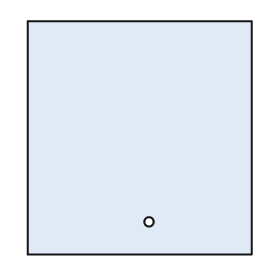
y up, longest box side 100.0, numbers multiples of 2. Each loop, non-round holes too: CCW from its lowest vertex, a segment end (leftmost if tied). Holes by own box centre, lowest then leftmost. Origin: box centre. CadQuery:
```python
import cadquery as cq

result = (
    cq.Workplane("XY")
    .moveTo(-48.0, -50.0)
    .lineTo(48.0, -50.0)
    .lineTo(48.0, 50.0)
    .lineTo(-48.0, 50.0)
    .close()
    .moveTo(4.0, -36.0)
    .circle(2.0)
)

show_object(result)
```